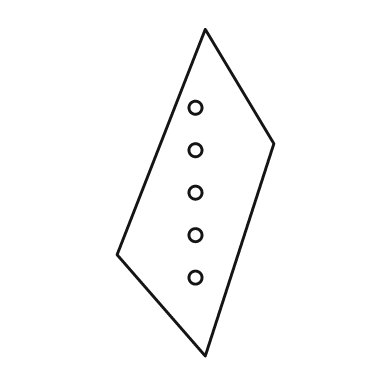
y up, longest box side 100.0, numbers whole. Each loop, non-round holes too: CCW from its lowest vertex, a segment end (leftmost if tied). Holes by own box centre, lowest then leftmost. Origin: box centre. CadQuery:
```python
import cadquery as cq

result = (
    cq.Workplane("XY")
    .moveTo(3.0, -50.0)
    .lineTo(24.0, 15.0)
    .lineTo(3.0, 50.0)
    .lineTo(-24.0, -19.0)
    .close()
    .moveTo(0.0, -26.0)
    .circle(2.0)
    .moveTo(0.0, -13.0)
    .circle(2.0)
    .moveTo(0.0, 0.0)
    .circle(2.0)
    .moveTo(0.0, 13.0)
    .circle(2.0)
    .moveTo(0.0, 26.0)
    .circle(2.0)
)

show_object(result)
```